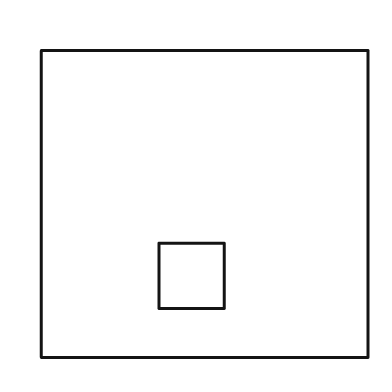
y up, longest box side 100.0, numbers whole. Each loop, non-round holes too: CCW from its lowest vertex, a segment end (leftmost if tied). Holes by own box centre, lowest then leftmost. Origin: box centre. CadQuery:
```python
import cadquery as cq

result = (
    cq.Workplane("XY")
    .moveTo(-50.0, -47.0)
    .lineTo(50.0, -47.0)
    .lineTo(50.0, 47.0)
    .lineTo(-50.0, 47.0)
    .close()
    .moveTo(-14.0, -32.0)
    .lineTo(6.0, -32.0)
    .lineTo(6.0, -12.0)
    .lineTo(-14.0, -12.0)
    .close()
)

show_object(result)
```